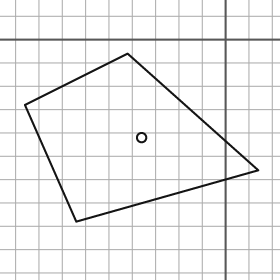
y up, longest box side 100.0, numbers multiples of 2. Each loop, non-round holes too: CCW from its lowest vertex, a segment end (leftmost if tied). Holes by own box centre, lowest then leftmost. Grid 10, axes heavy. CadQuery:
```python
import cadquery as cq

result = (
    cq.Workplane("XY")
    .moveTo(-64.0, -78.0)
    .lineTo(14.0, -56.0)
    .lineTo(-42.0, -6.0)
    .lineTo(-86.0, -28.0)
    .close()
    .moveTo(-36.0, -42.0)
    .circle(2.0)
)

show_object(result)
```